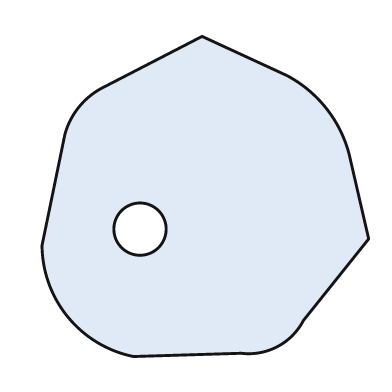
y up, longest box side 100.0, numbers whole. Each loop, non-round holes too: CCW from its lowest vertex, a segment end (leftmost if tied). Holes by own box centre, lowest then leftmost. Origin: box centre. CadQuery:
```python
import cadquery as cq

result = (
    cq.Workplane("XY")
    .moveTo(-22.0, -49.0)
    .lineTo(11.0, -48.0)
    .threePointArc((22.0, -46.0), (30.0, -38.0))
    .lineTo(50.0, -13.0)
    .lineTo(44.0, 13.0)
    .threePointArc((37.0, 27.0), (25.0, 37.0))
    .lineTo(-1.0, 49.0)
    .lineTo(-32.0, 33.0)
    .threePointArc((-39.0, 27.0), (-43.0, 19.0))
    .lineTo(-50.0, -15.0)
    .threePointArc((-42.0, -37.0), (-22.0, -49.0))
    .close()
    .moveTo(-20.0, -10.0)
    .circle(8.0)
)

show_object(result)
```